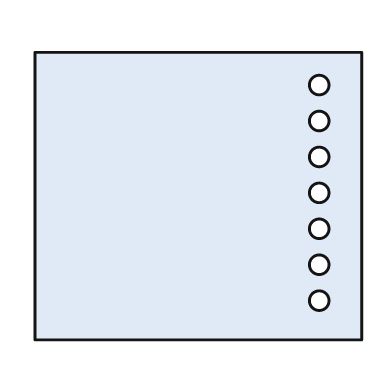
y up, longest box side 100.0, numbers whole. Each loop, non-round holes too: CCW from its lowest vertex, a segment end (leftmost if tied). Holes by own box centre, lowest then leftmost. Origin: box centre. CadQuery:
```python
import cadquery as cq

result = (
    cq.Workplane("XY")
    .moveTo(-50.0, -44.0)
    .lineTo(50.0, -44.0)
    .lineTo(50.0, 44.0)
    .lineTo(-50.0, 44.0)
    .close()
    .moveTo(37.0, -32.0)
    .circle(3.0)
    .moveTo(37.0, -21.0)
    .circle(3.0)
    .moveTo(37.0, -10.0)
    .circle(3.0)
    .moveTo(37.0, 1.0)
    .circle(3.0)
    .moveTo(37.0, 12.0)
    .circle(3.0)
    .moveTo(37.0, 23.0)
    .circle(3.0)
    .moveTo(37.0, 34.0)
    .circle(3.0)
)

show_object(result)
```